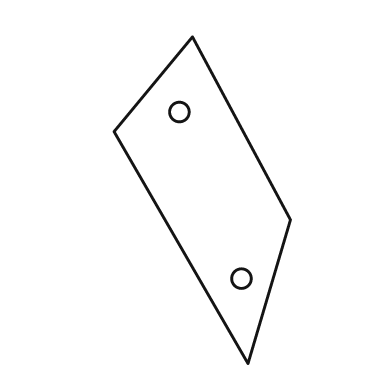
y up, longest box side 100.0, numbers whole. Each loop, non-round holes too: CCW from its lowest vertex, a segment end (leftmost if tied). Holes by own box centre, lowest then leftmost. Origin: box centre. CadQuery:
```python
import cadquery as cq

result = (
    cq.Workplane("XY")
    .moveTo(14.0, -50.0)
    .lineTo(27.0, -6.0)
    .lineTo(-3.0, 50.0)
    .lineTo(-27.0, 21.0)
    .close()
    .moveTo(12.0, -24.0)
    .circle(3.0)
    .moveTo(-7.0, 27.0)
    .circle(3.0)
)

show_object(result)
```